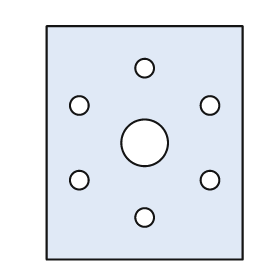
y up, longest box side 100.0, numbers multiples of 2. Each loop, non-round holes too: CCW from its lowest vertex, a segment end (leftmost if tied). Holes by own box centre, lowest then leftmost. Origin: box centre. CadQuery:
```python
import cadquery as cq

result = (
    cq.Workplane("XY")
    .moveTo(-42.0, -50.0)
    .lineTo(42.0, -50.0)
    .lineTo(42.0, 50.0)
    .lineTo(-42.0, 50.0)
    .close()
    .moveTo(0.0, -32.0)
    .circle(4.0)
    .moveTo(-28.0, -16.0)
    .circle(4.0)
    .moveTo(28.0, -16.0)
    .circle(4.0)
    .moveTo(0.0, 0.0)
    .circle(10.0)
    .moveTo(-28.0, 16.0)
    .circle(4.0)
    .moveTo(28.0, 16.0)
    .circle(4.0)
    .moveTo(0.0, 32.0)
    .circle(4.0)
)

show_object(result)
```